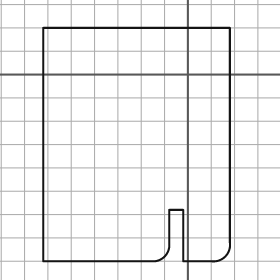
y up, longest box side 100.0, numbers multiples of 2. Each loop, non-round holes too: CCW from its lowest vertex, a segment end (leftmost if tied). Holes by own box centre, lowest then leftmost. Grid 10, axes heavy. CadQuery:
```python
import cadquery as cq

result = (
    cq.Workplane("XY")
    .moveTo(-62.0, -80.0)
    .lineTo(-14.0, -80.0)
    .threePointArc((-10.0, -78.0), (-8.0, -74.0))
    .lineTo(-8.0, -58.0)
    .lineTo(-2.0, -58.0)
    .lineTo(-2.0, -80.0)
    .lineTo(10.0, -80.0)
    .threePointArc((16.0, -78.0), (18.0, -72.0))
    .lineTo(18.0, 20.0)
    .lineTo(-62.0, 20.0)
    .close()
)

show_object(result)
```